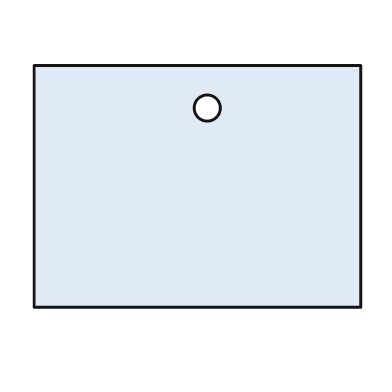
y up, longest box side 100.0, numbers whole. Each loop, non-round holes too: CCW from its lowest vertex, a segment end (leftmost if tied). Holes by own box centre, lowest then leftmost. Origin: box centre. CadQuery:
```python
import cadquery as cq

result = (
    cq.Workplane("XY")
    .moveTo(-50.0, -37.0)
    .lineTo(50.0, -37.0)
    .lineTo(50.0, 37.0)
    .lineTo(-50.0, 37.0)
    .close()
    .moveTo(3.0, 24.0)
    .circle(4.0)
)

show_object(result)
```